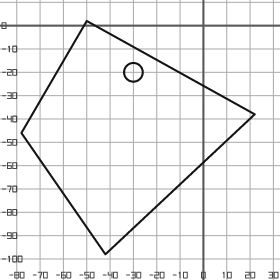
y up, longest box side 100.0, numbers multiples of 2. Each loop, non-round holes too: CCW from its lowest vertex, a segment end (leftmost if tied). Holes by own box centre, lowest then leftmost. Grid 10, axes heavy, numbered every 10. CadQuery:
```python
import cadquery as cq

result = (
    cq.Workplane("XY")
    .moveTo(-42.0, -98.0)
    .lineTo(22.0, -38.0)
    .lineTo(-50.0, 2.0)
    .lineTo(-78.0, -46.0)
    .close()
    .moveTo(-30.0, -20.0)
    .circle(4.0)
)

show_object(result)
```